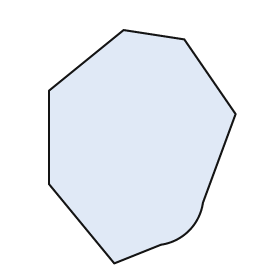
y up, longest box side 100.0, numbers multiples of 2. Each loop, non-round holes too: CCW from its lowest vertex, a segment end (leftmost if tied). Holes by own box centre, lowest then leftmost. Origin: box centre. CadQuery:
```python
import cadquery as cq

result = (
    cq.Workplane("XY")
    .moveTo(-12.0, -50.0)
    .lineTo(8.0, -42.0)
    .threePointArc((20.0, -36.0), (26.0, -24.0))
    .lineTo(40.0, 14.0)
    .lineTo(18.0, 46.0)
    .lineTo(-8.0, 50.0)
    .lineTo(-40.0, 24.0)
    .lineTo(-40.0, -16.0)
    .close()
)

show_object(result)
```